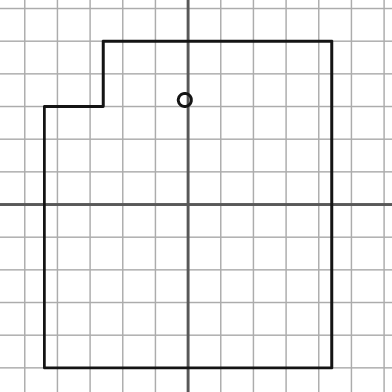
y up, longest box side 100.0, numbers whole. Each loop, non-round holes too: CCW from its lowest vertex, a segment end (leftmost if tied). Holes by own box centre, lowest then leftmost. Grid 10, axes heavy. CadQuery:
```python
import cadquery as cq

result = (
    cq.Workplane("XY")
    .moveTo(-44.0, -50.0)
    .lineTo(44.0, -50.0)
    .lineTo(44.0, 50.0)
    .lineTo(-26.0, 50.0)
    .lineTo(-26.0, 30.0)
    .lineTo(-44.0, 30.0)
    .close()
    .moveTo(-1.0, 32.0)
    .circle(2.0)
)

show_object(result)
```